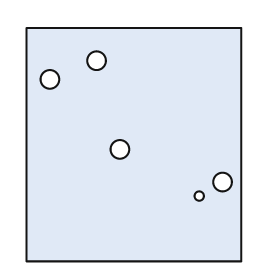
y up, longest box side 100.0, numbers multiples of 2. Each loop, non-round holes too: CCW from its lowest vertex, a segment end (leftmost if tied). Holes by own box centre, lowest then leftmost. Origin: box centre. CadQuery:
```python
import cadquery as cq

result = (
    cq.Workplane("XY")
    .moveTo(-46.0, -50.0)
    .lineTo(46.0, -50.0)
    .lineTo(46.0, 50.0)
    .lineTo(-46.0, 50.0)
    .close()
    .moveTo(28.0, -22.0)
    .circle(2.0)
    .moveTo(38.0, -16.0)
    .circle(4.0)
    .moveTo(-6.0, -2.0)
    .circle(4.0)
    .moveTo(-36.0, 28.0)
    .circle(4.0)
    .moveTo(-16.0, 36.0)
    .circle(4.0)
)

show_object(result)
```